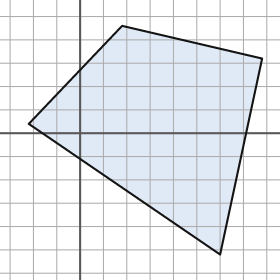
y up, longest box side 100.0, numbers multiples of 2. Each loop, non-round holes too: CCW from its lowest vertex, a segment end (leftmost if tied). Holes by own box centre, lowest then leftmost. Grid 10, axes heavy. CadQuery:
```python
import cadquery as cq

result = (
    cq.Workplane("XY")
    .moveTo(60.0, -52.0)
    .lineTo(78.0, 32.0)
    .lineTo(18.0, 46.0)
    .lineTo(-22.0, 4.0)
    .close()
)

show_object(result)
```